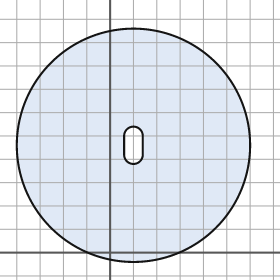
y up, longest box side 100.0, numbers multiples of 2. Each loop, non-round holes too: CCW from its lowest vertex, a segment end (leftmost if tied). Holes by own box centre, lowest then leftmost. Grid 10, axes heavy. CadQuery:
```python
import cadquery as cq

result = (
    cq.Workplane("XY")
    .moveTo(10.0, 46.0)
    .circle(50.0)
    .moveTo(6.0, 42.0)
    .threePointArc((10.0, 38.0), (14.0, 42.0))
    .lineTo(14.0, 50.0)
    .threePointArc((10.0, 54.0), (6.0, 50.0))
    .close()
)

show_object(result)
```